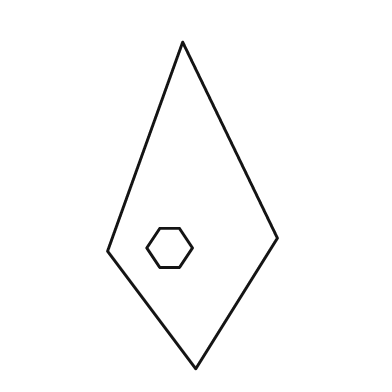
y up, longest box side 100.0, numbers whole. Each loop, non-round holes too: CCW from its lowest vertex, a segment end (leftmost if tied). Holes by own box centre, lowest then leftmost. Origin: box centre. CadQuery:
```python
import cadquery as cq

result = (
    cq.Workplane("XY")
    .moveTo(1.0, -50.0)
    .lineTo(26.0, -10.0)
    .lineTo(-3.0, 50.0)
    .lineTo(-26.0, -14.0)
    .close()
    .moveTo(-10.0, -19.0)
    .lineTo(-4.0, -19.0)
    .lineTo(0.0, -13.0)
    .lineTo(-4.0, -7.0)
    .lineTo(-10.0, -7.0)
    .lineTo(-14.0, -13.0)
    .close()
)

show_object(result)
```